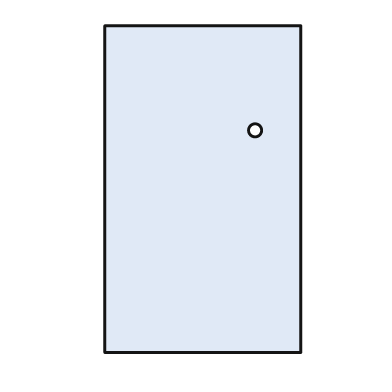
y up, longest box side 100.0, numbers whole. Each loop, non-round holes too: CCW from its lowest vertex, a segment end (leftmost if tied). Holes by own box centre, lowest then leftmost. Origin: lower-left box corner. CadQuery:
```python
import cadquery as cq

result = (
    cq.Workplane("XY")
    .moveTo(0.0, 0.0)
    .lineTo(60.0, 0.0)
    .lineTo(60.0, 100.0)
    .lineTo(0.0, 100.0)
    .close()
    .moveTo(46.0, 68.0)
    .circle(2.0)
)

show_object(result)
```